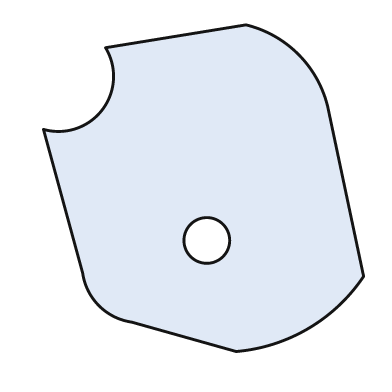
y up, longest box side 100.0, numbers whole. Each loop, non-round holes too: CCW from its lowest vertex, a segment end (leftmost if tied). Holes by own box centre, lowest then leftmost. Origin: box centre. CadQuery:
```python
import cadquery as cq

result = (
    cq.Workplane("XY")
    .moveTo(10.0, -50.0)
    .threePointArc((32.0, -43.0), (49.0, -27.0))
    .lineTo(38.0, 25.0)
    .threePointArc((29.0, 41.0), (13.0, 50.0))
    .lineTo(-30.0, 43.0)
    .threePointArc((-31.0, 24.0), (-49.0, 18.0))
    .lineTo(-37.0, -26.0)
    .threePointArc((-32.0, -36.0), (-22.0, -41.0))
    .close()
    .moveTo(1.0, -16.0)
    .circle(7.0)
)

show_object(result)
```